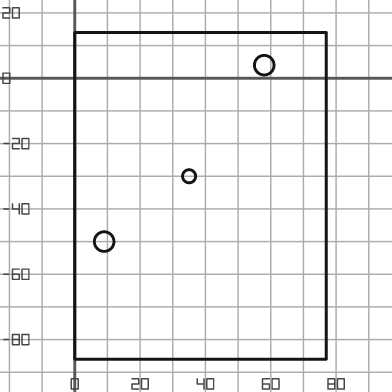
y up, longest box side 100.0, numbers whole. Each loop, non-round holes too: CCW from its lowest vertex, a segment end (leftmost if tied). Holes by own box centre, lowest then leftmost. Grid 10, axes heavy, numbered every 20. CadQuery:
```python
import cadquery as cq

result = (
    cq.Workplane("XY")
    .moveTo(0.0, -86.0)
    .lineTo(77.0, -86.0)
    .lineTo(77.0, 14.0)
    .lineTo(0.0, 14.0)
    .close()
    .moveTo(9.0, -50.0)
    .circle(3.0)
    .moveTo(35.0, -30.0)
    .circle(2.0)
    .moveTo(58.0, 4.0)
    .circle(3.0)
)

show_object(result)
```